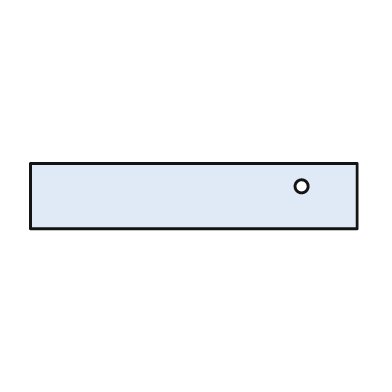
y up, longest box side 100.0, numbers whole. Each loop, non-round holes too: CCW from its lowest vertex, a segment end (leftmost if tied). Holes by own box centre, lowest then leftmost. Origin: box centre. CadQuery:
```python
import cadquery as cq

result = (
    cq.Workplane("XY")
    .moveTo(-50.0, -10.0)
    .lineTo(50.0, -10.0)
    .lineTo(50.0, 10.0)
    .lineTo(-50.0, 10.0)
    .close()
    .moveTo(33.0, 3.0)
    .circle(2.0)
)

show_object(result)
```